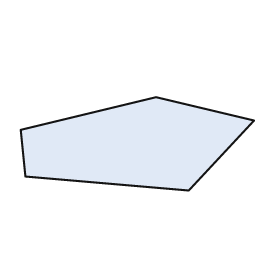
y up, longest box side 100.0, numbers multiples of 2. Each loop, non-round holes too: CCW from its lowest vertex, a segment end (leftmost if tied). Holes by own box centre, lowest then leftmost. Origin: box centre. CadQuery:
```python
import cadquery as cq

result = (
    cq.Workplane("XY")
    .moveTo(22.0, -20.0)
    .lineTo(50.0, 10.0)
    .lineTo(8.0, 20.0)
    .lineTo(-50.0, 6.0)
    .lineTo(-48.0, -14.0)
    .close()
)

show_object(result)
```